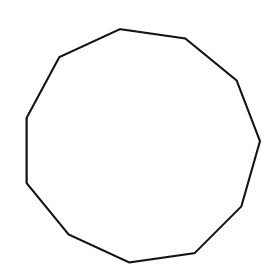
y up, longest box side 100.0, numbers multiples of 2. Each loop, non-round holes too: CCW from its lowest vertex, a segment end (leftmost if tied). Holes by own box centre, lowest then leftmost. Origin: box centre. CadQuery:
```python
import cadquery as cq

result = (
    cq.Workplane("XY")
    .moveTo(-6.0, -50.0)
    .lineTo(22.0, -46.0)
    .lineTo(42.0, -26.0)
    .lineTo(50.0, 2.0)
    .lineTo(40.0, 28.0)
    .lineTo(18.0, 46.0)
    .lineTo(-10.0, 50.0)
    .lineTo(-36.0, 38.0)
    .lineTo(-50.0, 12.0)
    .lineTo(-50.0, -16.0)
    .lineTo(-32.0, -38.0)
    .close()
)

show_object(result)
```